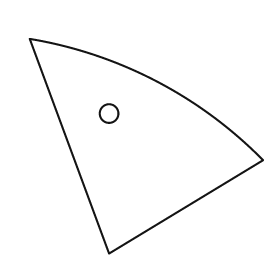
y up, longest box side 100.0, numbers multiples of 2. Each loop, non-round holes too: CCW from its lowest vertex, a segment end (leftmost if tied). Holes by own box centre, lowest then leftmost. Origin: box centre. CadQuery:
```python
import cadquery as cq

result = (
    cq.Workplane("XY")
    .moveTo(-16.0, -46.0)
    .lineTo(50.0, -6.0)
    .threePointArc((4.0, 28.0), (-50.0, 46.0))
    .close()
    .moveTo(-16.0, 14.0)
    .circle(4.0)
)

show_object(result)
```